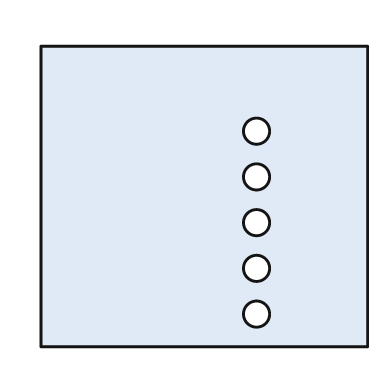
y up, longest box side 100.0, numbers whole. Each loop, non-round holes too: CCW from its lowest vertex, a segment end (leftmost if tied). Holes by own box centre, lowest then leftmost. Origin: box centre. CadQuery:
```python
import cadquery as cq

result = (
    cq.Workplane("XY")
    .moveTo(-50.0, -46.0)
    .lineTo(50.0, -46.0)
    .lineTo(50.0, 46.0)
    .lineTo(-50.0, 46.0)
    .close()
    .moveTo(16.0, -36.0)
    .circle(4.0)
    .moveTo(16.0, -22.0)
    .circle(4.0)
    .moveTo(16.0, -8.0)
    .circle(4.0)
    .moveTo(16.0, 6.0)
    .circle(4.0)
    .moveTo(16.0, 20.0)
    .circle(4.0)
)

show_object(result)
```